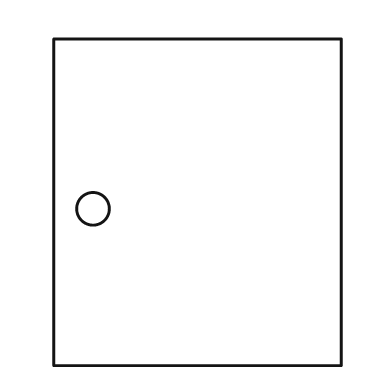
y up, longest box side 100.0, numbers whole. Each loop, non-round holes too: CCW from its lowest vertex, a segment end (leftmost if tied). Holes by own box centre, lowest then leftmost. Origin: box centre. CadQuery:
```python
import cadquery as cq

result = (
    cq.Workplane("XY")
    .moveTo(-44.0, -50.0)
    .lineTo(44.0, -50.0)
    .lineTo(44.0, 50.0)
    .lineTo(-44.0, 50.0)
    .close()
    .moveTo(-32.0, -2.0)
    .circle(5.0)
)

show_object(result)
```